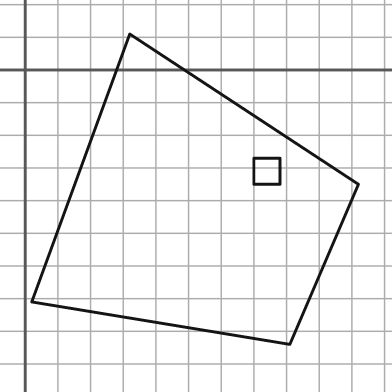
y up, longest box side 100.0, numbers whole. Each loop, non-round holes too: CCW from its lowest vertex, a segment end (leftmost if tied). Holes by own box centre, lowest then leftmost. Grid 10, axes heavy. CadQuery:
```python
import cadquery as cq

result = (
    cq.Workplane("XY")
    .moveTo(81.0, -84.0)
    .lineTo(102.0, -35.0)
    .lineTo(32.0, 11.0)
    .lineTo(2.0, -71.0)
    .close()
    .moveTo(70.0, -35.0)
    .lineTo(78.0, -35.0)
    .lineTo(78.0, -27.0)
    .lineTo(70.0, -27.0)
    .close()
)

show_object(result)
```